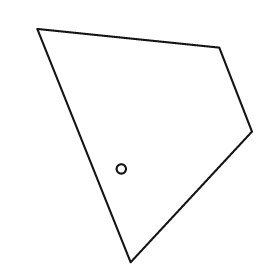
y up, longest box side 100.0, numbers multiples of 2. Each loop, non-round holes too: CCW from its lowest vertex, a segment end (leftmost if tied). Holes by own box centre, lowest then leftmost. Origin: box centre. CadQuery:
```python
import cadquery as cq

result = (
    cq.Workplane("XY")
    .moveTo(-6.0, -50.0)
    .lineTo(46.0, 6.0)
    .lineTo(32.0, 42.0)
    .lineTo(-46.0, 50.0)
    .close()
    .moveTo(-10.0, -10.0)
    .circle(2.0)
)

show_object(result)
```